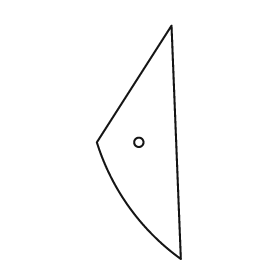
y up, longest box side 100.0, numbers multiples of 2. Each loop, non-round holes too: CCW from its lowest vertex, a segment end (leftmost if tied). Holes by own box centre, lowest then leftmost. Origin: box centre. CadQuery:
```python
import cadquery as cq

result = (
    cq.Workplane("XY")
    .moveTo(18.0, -50.0)
    .lineTo(14.0, 50.0)
    .lineTo(-18.0, 0.0)
    .threePointArc((-4.0, -28.0), (18.0, -50.0))
    .close()
    .moveTo(0.0, 0.0)
    .circle(2.0)
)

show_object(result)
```